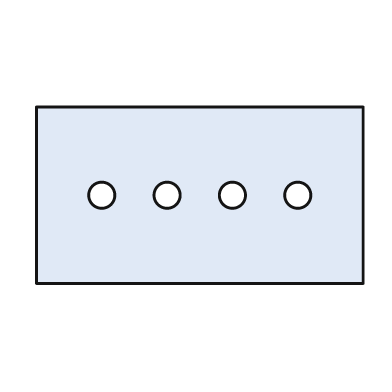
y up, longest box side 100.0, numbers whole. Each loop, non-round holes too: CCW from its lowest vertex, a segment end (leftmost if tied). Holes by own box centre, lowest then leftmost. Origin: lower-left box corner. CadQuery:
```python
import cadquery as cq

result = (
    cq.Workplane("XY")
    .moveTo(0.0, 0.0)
    .lineTo(100.0, 0.0)
    .lineTo(100.0, 54.0)
    .lineTo(0.0, 54.0)
    .close()
    .moveTo(20.0, 27.0)
    .circle(4.0)
    .moveTo(40.0, 27.0)
    .circle(4.0)
    .moveTo(60.0, 27.0)
    .circle(4.0)
    .moveTo(80.0, 27.0)
    .circle(4.0)
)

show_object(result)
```